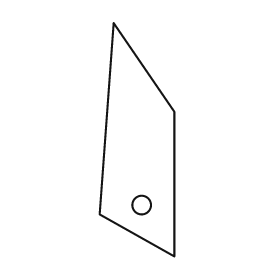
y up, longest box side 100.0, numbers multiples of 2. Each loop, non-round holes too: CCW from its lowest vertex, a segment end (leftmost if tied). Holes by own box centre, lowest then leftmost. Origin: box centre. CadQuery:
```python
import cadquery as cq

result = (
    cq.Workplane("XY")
    .moveTo(16.0, -50.0)
    .lineTo(16.0, 12.0)
    .lineTo(-10.0, 50.0)
    .lineTo(-16.0, -32.0)
    .close()
    .moveTo(2.0, -28.0)
    .circle(4.0)
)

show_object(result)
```